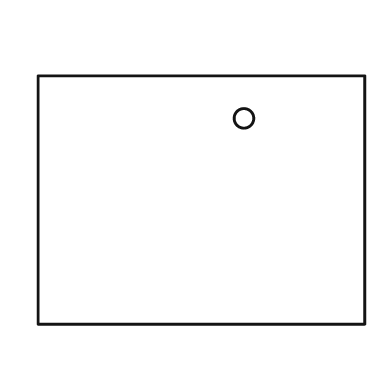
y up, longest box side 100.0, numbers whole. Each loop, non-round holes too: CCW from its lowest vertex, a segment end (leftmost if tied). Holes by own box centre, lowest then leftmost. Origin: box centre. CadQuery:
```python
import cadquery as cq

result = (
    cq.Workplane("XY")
    .moveTo(-50.0, -38.0)
    .lineTo(50.0, -38.0)
    .lineTo(50.0, 38.0)
    .lineTo(-50.0, 38.0)
    .close()
    .moveTo(13.0, 25.0)
    .circle(3.0)
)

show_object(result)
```